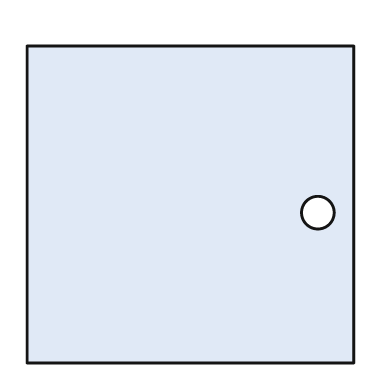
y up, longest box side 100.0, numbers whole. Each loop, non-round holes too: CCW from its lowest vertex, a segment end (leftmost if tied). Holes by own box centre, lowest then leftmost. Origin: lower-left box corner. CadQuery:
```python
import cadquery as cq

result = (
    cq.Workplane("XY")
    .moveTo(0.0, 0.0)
    .lineTo(100.0, 0.0)
    .lineTo(100.0, 97.0)
    .lineTo(0.0, 97.0)
    .close()
    .moveTo(89.0, 46.0)
    .circle(5.0)
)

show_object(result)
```